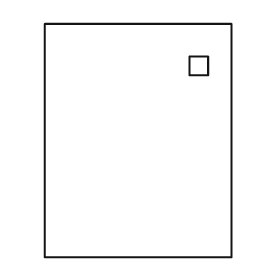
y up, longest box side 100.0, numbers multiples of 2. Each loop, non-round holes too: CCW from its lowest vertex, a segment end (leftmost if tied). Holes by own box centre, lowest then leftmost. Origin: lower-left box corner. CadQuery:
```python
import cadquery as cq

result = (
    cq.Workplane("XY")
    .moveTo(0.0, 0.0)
    .lineTo(80.0, 0.0)
    .lineTo(80.0, 100.0)
    .lineTo(0.0, 100.0)
    .close()
    .moveTo(62.0, 78.0)
    .lineTo(70.0, 78.0)
    .lineTo(70.0, 86.0)
    .lineTo(62.0, 86.0)
    .close()
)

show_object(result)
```